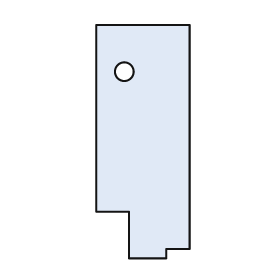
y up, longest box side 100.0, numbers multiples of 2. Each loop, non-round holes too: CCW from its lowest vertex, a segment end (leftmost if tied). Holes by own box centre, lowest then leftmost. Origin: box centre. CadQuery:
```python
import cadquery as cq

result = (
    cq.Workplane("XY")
    .moveTo(-6.0, -50.0)
    .lineTo(10.0, -50.0)
    .lineTo(10.0, -46.0)
    .lineTo(20.0, -46.0)
    .lineTo(20.0, 50.0)
    .lineTo(-20.0, 50.0)
    .lineTo(-20.0, -30.0)
    .lineTo(-6.0, -30.0)
    .close()
    .moveTo(-8.0, 30.0)
    .circle(4.0)
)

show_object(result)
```